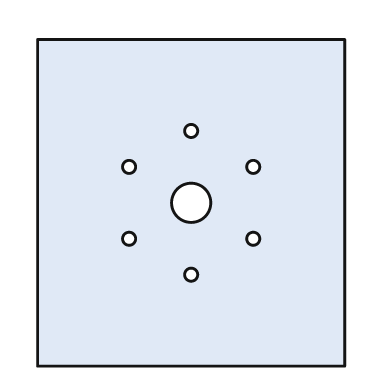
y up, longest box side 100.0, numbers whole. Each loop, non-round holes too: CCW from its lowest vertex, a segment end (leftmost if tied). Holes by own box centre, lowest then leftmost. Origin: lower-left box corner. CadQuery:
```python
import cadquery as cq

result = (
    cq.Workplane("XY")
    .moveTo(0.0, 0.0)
    .lineTo(94.0, 0.0)
    .lineTo(94.0, 100.0)
    .lineTo(0.0, 100.0)
    .close()
    .moveTo(47.0, 28.0)
    .circle(2.0)
    .moveTo(28.0, 39.0)
    .circle(2.0)
    .moveTo(66.0, 39.0)
    .circle(2.0)
    .moveTo(47.0, 50.0)
    .circle(6.0)
    .moveTo(28.0, 61.0)
    .circle(2.0)
    .moveTo(66.0, 61.0)
    .circle(2.0)
    .moveTo(47.0, 72.0)
    .circle(2.0)
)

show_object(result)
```